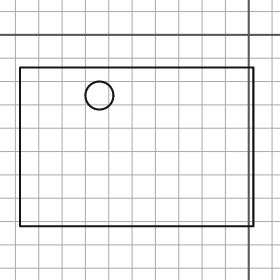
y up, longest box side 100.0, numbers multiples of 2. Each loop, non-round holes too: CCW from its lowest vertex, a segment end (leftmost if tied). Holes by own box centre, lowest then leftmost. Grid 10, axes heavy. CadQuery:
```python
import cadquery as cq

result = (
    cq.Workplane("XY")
    .moveTo(-98.0, -82.0)
    .lineTo(2.0, -82.0)
    .lineTo(2.0, -14.0)
    .lineTo(-98.0, -14.0)
    .close()
    .moveTo(-64.0, -26.0)
    .circle(6.0)
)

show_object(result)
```